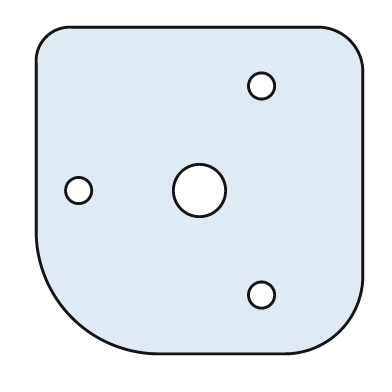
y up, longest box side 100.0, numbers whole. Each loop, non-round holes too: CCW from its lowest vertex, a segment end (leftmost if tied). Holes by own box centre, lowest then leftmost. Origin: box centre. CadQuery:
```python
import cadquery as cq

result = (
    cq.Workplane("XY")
    .moveTo(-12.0, -50.0)
    .lineTo(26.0, -50.0)
    .threePointArc((43.0, -43.0), (50.0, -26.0))
    .lineTo(50.0, 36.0)
    .threePointArc((46.0, 46.0), (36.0, 50.0))
    .lineTo(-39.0, 50.0)
    .threePointArc((-47.0, 47.0), (-50.0, 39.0))
    .lineTo(-50.0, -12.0)
    .threePointArc((-39.0, -39.0), (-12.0, -50.0))
    .close()
    .moveTo(19.0, -32.0)
    .circle(4.0)
    .moveTo(-37.0, 0.0)
    .circle(4.0)
    .moveTo(0.0, 0.0)
    .circle(8.0)
    .moveTo(19.0, 32.0)
    .circle(4.0)
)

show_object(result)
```